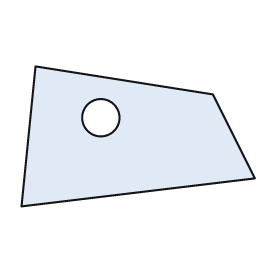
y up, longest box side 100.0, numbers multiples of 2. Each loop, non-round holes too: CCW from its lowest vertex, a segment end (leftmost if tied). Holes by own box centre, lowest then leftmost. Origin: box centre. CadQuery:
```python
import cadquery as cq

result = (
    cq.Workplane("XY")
    .moveTo(-50.0, -30.0)
    .lineTo(50.0, -18.0)
    .lineTo(32.0, 18.0)
    .lineTo(-44.0, 30.0)
    .close()
    .moveTo(-16.0, 8.0)
    .circle(8.0)
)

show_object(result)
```